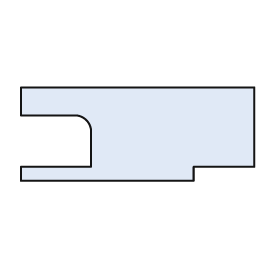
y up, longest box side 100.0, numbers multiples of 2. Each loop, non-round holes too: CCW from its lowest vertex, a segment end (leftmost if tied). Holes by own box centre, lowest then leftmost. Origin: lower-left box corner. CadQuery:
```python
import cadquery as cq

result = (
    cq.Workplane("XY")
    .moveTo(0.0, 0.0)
    .lineTo(74.0, 0.0)
    .lineTo(74.0, 6.0)
    .lineTo(100.0, 6.0)
    .lineTo(100.0, 40.0)
    .lineTo(0.0, 40.0)
    .lineTo(0.0, 28.0)
    .lineTo(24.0, 28.0)
    .threePointArc((28.0, 26.0), (30.0, 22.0))
    .lineTo(30.0, 6.0)
    .lineTo(0.0, 6.0)
    .close()
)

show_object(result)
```